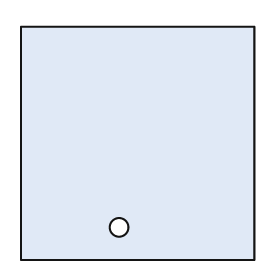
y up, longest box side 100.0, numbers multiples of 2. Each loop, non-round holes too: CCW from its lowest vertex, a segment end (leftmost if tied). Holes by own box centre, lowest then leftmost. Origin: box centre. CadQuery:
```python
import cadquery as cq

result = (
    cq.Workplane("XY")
    .moveTo(-50.0, -50.0)
    .lineTo(50.0, -50.0)
    .lineTo(50.0, 50.0)
    .lineTo(-50.0, 50.0)
    .close()
    .moveTo(-8.0, -36.0)
    .circle(4.0)
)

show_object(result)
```